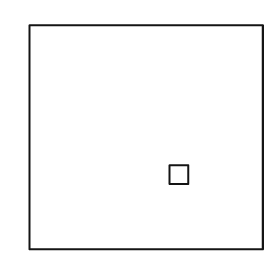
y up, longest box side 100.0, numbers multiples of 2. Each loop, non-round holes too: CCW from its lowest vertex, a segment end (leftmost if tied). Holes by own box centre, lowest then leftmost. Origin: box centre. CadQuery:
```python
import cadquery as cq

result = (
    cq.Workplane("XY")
    .moveTo(-50.0, -48.0)
    .lineTo(50.0, -48.0)
    .lineTo(50.0, 48.0)
    .lineTo(-50.0, 48.0)
    .close()
    .moveTo(10.0, -20.0)
    .lineTo(18.0, -20.0)
    .lineTo(18.0, -12.0)
    .lineTo(10.0, -12.0)
    .close()
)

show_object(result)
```